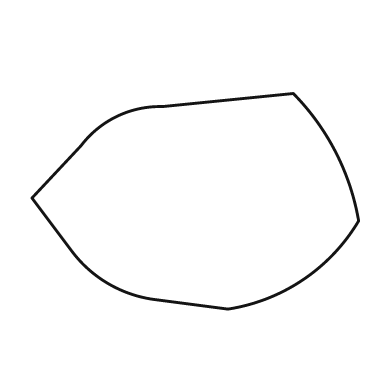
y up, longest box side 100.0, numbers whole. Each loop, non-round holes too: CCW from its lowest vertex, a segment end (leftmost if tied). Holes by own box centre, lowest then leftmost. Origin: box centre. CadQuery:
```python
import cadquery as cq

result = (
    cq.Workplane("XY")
    .moveTo(10.0, -33.0)
    .threePointArc((33.0, -24.0), (50.0, -6.0))
    .threePointArc((43.0, 15.0), (30.0, 33.0))
    .lineTo(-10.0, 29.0)
    .threePointArc((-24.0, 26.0), (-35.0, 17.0))
    .lineTo(-50.0, 1.0)
    .lineTo(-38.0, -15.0)
    .threePointArc((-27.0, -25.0), (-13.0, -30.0))
    .close()
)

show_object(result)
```